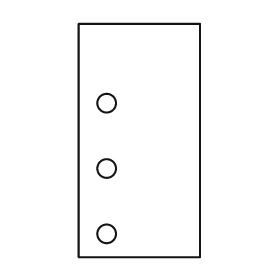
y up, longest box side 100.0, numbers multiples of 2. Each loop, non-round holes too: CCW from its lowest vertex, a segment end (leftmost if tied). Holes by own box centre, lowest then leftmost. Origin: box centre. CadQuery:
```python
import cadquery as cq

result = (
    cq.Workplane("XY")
    .moveTo(-26.0, -50.0)
    .lineTo(26.0, -50.0)
    .lineTo(26.0, 50.0)
    .lineTo(-26.0, 50.0)
    .close()
    .moveTo(-14.0, -40.0)
    .circle(4.0)
    .moveTo(-14.0, -12.0)
    .circle(4.0)
    .moveTo(-14.0, 16.0)
    .circle(4.0)
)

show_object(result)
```